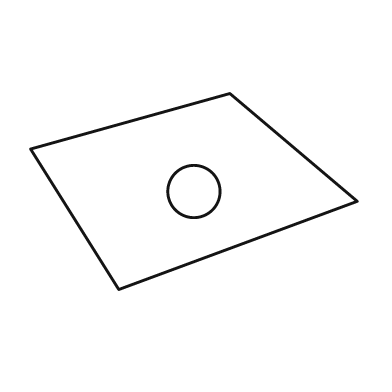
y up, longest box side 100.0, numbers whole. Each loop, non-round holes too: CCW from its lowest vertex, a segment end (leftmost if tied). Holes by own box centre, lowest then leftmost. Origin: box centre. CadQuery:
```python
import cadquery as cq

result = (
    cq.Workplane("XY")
    .moveTo(-23.0, -30.0)
    .lineTo(50.0, -3.0)
    .lineTo(11.0, 30.0)
    .lineTo(-50.0, 13.0)
    .close()
    .moveTo(0.0, 0.0)
    .circle(8.0)
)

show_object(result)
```